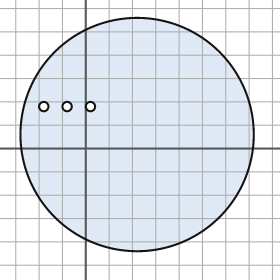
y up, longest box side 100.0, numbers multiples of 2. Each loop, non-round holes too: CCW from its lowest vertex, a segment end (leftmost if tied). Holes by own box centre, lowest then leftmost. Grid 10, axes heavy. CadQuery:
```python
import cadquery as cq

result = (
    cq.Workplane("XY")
    .moveTo(22.0, 6.0)
    .circle(50.0)
    .moveTo(-18.0, 18.0)
    .circle(2.0)
    .moveTo(-8.0, 18.0)
    .circle(2.0)
    .moveTo(2.0, 18.0)
    .circle(2.0)
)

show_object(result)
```